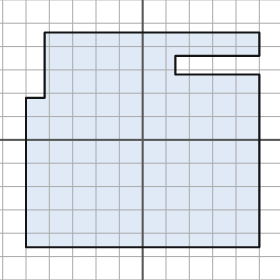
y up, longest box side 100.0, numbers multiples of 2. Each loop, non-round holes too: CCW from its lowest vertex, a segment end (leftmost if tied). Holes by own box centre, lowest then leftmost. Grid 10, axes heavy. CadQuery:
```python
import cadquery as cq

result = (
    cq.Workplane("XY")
    .moveTo(-50.0, -46.0)
    .lineTo(50.0, -46.0)
    .lineTo(50.0, 28.0)
    .lineTo(14.0, 28.0)
    .lineTo(14.0, 36.0)
    .lineTo(50.0, 36.0)
    .lineTo(50.0, 46.0)
    .lineTo(-42.0, 46.0)
    .lineTo(-42.0, 18.0)
    .lineTo(-50.0, 18.0)
    .close()
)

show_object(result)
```